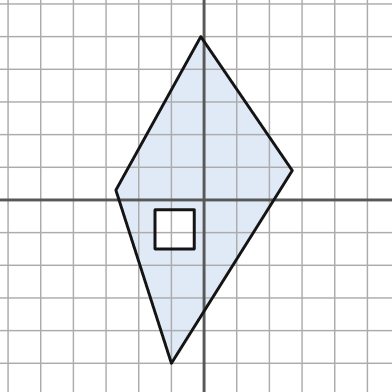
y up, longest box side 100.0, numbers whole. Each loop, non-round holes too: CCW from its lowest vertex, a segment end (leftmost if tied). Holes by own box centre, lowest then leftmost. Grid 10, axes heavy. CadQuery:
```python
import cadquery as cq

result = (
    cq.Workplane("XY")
    .moveTo(-10.0, -50.0)
    .lineTo(27.0, 9.0)
    .lineTo(-1.0, 50.0)
    .lineTo(-27.0, 3.0)
    .close()
    .moveTo(-15.0, -15.0)
    .lineTo(-3.0, -15.0)
    .lineTo(-3.0, -3.0)
    .lineTo(-15.0, -3.0)
    .close()
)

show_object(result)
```